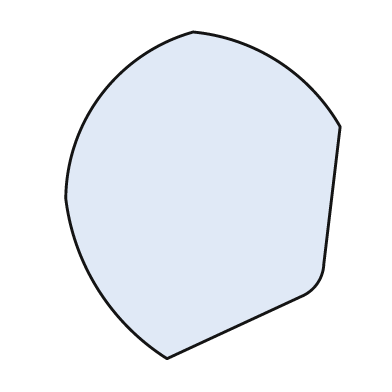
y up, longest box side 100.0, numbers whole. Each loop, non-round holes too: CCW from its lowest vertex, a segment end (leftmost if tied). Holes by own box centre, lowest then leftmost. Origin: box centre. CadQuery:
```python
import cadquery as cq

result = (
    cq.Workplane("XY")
    .moveTo(-11.0, -50.0)
    .lineTo(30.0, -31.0)
    .threePointArc((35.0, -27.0), (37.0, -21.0))
    .lineTo(42.0, 21.0)
    .threePointArc((23.0, 41.0), (-3.0, 50.0))
    .threePointArc((-31.0, 31.0), (-42.0, -1.0))
    .threePointArc((-32.0, -29.0), (-11.0, -50.0))
    .close()
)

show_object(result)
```